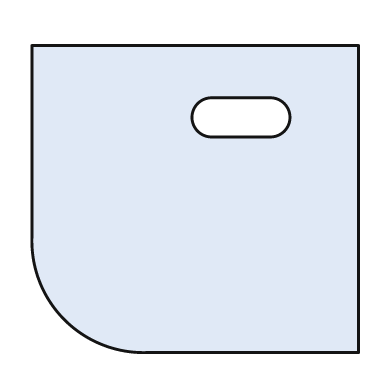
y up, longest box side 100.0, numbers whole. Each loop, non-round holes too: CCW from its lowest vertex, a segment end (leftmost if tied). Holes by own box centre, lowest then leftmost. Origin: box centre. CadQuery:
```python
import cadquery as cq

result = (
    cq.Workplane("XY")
    .moveTo(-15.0, -47.0)
    .lineTo(50.0, -47.0)
    .lineTo(50.0, 47.0)
    .lineTo(-50.0, 47.0)
    .lineTo(-50.0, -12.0)
    .threePointArc((-40.0, -37.0), (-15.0, -47.0))
    .close()
    .moveTo(5.0, 19.0)
    .lineTo(23.0, 19.0)
    .threePointArc((29.0, 25.0), (23.0, 31.0))
    .lineTo(5.0, 31.0)
    .threePointArc((-1.0, 25.0), (5.0, 19.0))
    .close()
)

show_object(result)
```